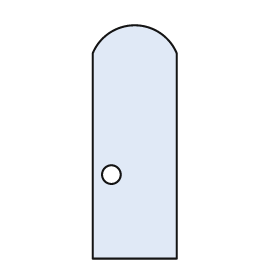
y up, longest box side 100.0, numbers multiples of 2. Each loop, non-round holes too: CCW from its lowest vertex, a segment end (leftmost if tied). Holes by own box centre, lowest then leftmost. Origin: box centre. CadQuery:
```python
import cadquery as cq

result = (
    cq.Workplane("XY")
    .moveTo(-18.0, -50.0)
    .lineTo(18.0, -50.0)
    .lineTo(18.0, 38.0)
    .threePointArc((0.0, 50.0), (-18.0, 38.0))
    .close()
    .moveTo(-10.0, -14.0)
    .circle(4.0)
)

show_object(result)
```